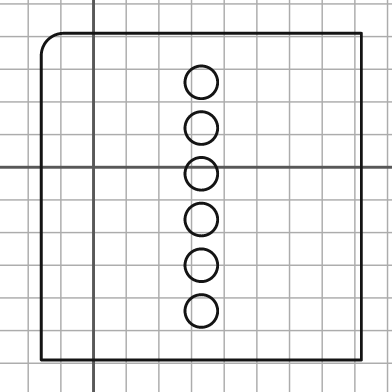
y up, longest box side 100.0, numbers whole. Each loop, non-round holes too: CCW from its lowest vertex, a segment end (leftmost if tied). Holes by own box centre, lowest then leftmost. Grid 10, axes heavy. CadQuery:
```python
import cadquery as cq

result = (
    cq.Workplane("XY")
    .moveTo(-16.0, -59.0)
    .lineTo(82.0, -59.0)
    .lineTo(82.0, 41.0)
    .lineTo(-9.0, 41.0)
    .threePointArc((-14.0, 39.0), (-16.0, 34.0))
    .close()
    .moveTo(33.0, -44.0)
    .circle(5.0)
    .moveTo(33.0, -30.0)
    .circle(5.0)
    .moveTo(33.0, -16.0)
    .circle(5.0)
    .moveTo(33.0, -2.0)
    .circle(5.0)
    .moveTo(33.0, 12.0)
    .circle(5.0)
    .moveTo(33.0, 26.0)
    .circle(5.0)
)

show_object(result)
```